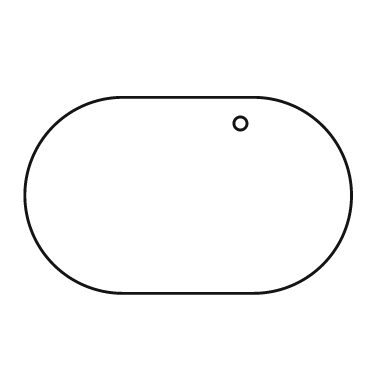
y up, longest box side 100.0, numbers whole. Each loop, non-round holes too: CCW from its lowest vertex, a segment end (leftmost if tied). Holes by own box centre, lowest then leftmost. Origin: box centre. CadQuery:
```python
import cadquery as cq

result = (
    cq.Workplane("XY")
    .moveTo(-20.0, -30.0)
    .lineTo(20.0, -30.0)
    .threePointArc((50.0, 0.0), (20.0, 30.0))
    .lineTo(-20.0, 30.0)
    .threePointArc((-50.0, 0.0), (-20.0, -30.0))
    .close()
    .moveTo(16.0, 22.0)
    .circle(2.0)
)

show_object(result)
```